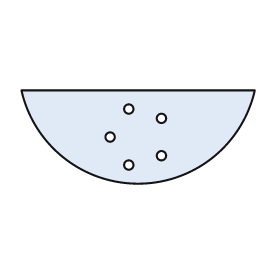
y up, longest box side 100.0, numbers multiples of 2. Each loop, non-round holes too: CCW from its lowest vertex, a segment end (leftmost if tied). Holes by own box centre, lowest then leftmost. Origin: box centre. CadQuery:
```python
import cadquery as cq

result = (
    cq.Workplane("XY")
    .moveTo(-50.0, 20.0)
    .threePointArc((0.0, -20.0), (50.0, 20.0))
    .close()
    .moveTo(-4.0, -12.0)
    .circle(2.0)
    .moveTo(10.0, -8.0)
    .circle(2.0)
    .moveTo(-12.0, 0.0)
    .circle(2.0)
    .moveTo(10.0, 8.0)
    .circle(2.0)
    .moveTo(-4.0, 12.0)
    .circle(2.0)
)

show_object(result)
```